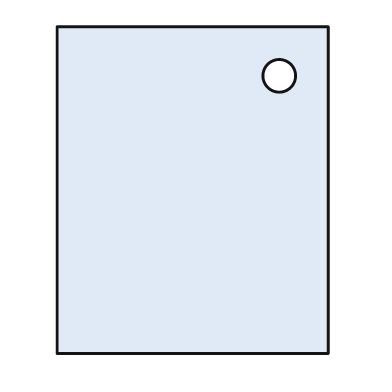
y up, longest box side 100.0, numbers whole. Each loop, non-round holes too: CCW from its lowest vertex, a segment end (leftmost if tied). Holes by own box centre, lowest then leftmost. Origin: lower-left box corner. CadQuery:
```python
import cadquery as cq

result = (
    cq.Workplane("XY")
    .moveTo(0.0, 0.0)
    .lineTo(83.0, 0.0)
    .lineTo(83.0, 100.0)
    .lineTo(0.0, 100.0)
    .close()
    .moveTo(68.0, 85.0)
    .circle(5.0)
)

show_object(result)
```